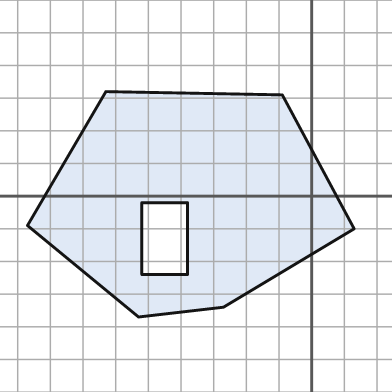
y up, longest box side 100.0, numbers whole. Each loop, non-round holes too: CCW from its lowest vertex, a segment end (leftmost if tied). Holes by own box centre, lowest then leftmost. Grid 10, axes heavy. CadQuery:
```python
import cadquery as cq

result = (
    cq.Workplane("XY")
    .moveTo(-53.0, -37.0)
    .lineTo(-27.0, -34.0)
    .lineTo(13.0, -10.0)
    .lineTo(-9.0, 31.0)
    .lineTo(-63.0, 32.0)
    .lineTo(-87.0, -9.0)
    .close()
    .moveTo(-52.0, -24.0)
    .lineTo(-38.0, -24.0)
    .lineTo(-38.0, -2.0)
    .lineTo(-52.0, -2.0)
    .close()
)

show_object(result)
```